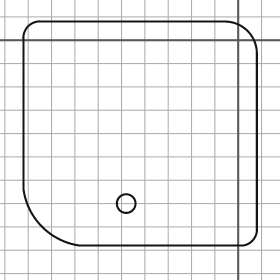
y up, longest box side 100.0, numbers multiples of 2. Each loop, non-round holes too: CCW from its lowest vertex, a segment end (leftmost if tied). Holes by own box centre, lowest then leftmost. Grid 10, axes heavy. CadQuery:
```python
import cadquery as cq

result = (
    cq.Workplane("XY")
    .moveTo(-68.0, -88.0)
    .lineTo(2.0, -88.0)
    .threePointArc((6.0, -86.0), (8.0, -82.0))
    .lineTo(8.0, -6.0)
    .threePointArc((4.0, 4.0), (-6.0, 8.0))
    .lineTo(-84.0, 8.0)
    .threePointArc((-90.0, 6.0), (-92.0, 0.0))
    .lineTo(-92.0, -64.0)
    .threePointArc((-84.0, -80.0), (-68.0, -88.0))
    .close()
    .moveTo(-48.0, -70.0)
    .circle(4.0)
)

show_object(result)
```